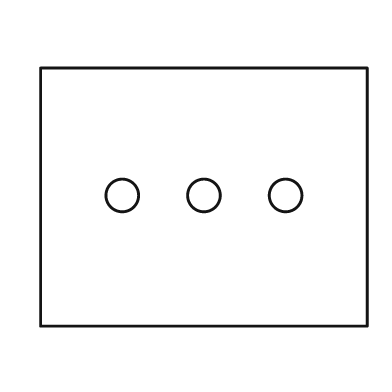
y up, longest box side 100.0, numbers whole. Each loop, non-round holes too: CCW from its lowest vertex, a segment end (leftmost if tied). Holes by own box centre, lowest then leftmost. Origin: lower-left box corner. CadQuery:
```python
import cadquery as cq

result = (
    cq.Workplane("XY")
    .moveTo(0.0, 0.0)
    .lineTo(100.0, 0.0)
    .lineTo(100.0, 79.0)
    .lineTo(0.0, 79.0)
    .close()
    .moveTo(25.0, 40.0)
    .circle(5.0)
    .moveTo(50.0, 40.0)
    .circle(5.0)
    .moveTo(75.0, 40.0)
    .circle(5.0)
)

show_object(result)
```